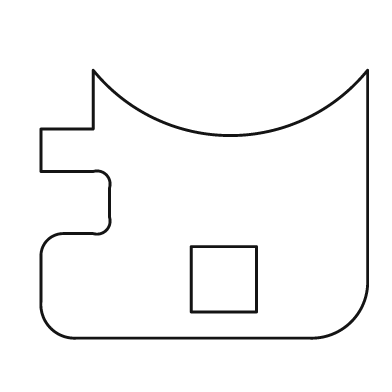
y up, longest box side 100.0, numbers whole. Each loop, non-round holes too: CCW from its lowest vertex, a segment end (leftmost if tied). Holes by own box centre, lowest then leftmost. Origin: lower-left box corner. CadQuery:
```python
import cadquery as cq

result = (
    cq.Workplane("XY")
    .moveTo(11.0, 0.0)
    .lineTo(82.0, 0.0)
    .threePointArc((95.0, 5.0), (100.0, 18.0))
    .lineTo(100.0, 82.0)
    .threePointArc((58.0, 62.0), (16.0, 82.0))
    .lineTo(16.0, 64.0)
    .lineTo(0.0, 64.0)
    .lineTo(0.0, 51.0)
    .lineTo(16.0, 51.0)
    .threePointArc((20.0, 50.0), (21.0, 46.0))
    .lineTo(21.0, 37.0)
    .threePointArc((20.0, 33.0), (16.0, 32.0))
    .lineTo(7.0, 32.0)
    .threePointArc((2.0, 30.0), (0.0, 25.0))
    .lineTo(0.0, 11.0)
    .threePointArc((3.0, 3.0), (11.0, 0.0))
    .close()
    .moveTo(46.0, 8.0)
    .lineTo(66.0, 8.0)
    .lineTo(66.0, 28.0)
    .lineTo(46.0, 28.0)
    .close()
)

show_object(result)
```